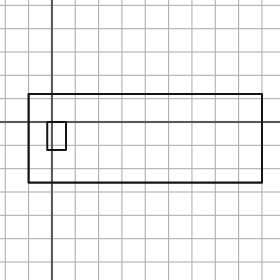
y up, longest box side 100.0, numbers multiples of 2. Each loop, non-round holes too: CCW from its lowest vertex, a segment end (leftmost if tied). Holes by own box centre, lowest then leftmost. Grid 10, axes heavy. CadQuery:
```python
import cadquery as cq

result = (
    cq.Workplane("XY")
    .moveTo(-10.0, -26.0)
    .lineTo(90.0, -26.0)
    .lineTo(90.0, 12.0)
    .lineTo(-10.0, 12.0)
    .close()
    .moveTo(-2.0, -12.0)
    .lineTo(6.0, -12.0)
    .lineTo(6.0, 0.0)
    .lineTo(-2.0, 0.0)
    .close()
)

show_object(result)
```